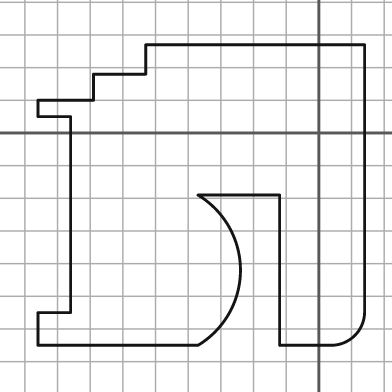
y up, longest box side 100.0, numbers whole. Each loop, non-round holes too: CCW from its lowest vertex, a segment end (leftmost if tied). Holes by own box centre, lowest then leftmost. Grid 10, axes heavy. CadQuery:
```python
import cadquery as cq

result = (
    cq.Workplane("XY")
    .moveTo(-86.0, -65.0)
    .lineTo(-37.0, -65.0)
    .threePointArc((-24.0, -42.0), (-37.0, -19.0))
    .lineTo(-12.0, -19.0)
    .lineTo(-12.0, -65.0)
    .lineTo(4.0, -65.0)
    .threePointArc((11.0, -62.0), (14.0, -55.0))
    .lineTo(14.0, 27.0)
    .lineTo(-53.0, 27.0)
    .lineTo(-53.0, 18.0)
    .lineTo(-69.0, 18.0)
    .lineTo(-69.0, 10.0)
    .lineTo(-86.0, 10.0)
    .lineTo(-86.0, 5.0)
    .lineTo(-76.0, 5.0)
    .lineTo(-76.0, -55.0)
    .lineTo(-86.0, -55.0)
    .close()
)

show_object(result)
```